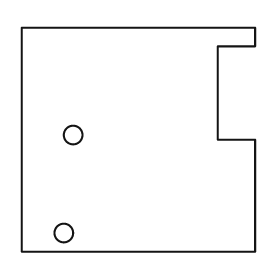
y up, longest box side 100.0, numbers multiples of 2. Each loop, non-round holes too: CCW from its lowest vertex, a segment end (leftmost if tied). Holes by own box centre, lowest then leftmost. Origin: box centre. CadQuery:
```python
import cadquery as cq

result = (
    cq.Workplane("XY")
    .moveTo(-50.0, -48.0)
    .lineTo(50.0, -48.0)
    .lineTo(50.0, 0.0)
    .lineTo(34.0, 0.0)
    .lineTo(34.0, 40.0)
    .lineTo(50.0, 40.0)
    .lineTo(50.0, 48.0)
    .lineTo(-50.0, 48.0)
    .close()
    .moveTo(-32.0, -40.0)
    .circle(4.0)
    .moveTo(-28.0, 2.0)
    .circle(4.0)
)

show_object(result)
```